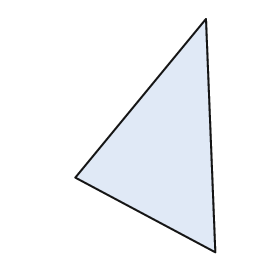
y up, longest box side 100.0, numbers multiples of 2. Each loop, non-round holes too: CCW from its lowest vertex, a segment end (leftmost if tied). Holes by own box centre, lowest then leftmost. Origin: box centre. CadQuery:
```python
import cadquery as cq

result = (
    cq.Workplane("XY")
    .moveTo(30.0, -50.0)
    .lineTo(26.0, 50.0)
    .lineTo(-30.0, -18.0)
    .close()
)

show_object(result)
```